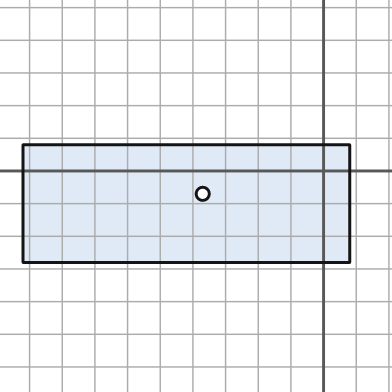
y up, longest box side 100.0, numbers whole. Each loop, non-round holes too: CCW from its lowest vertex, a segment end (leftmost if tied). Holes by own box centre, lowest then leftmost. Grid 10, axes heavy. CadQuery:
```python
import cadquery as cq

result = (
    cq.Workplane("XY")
    .moveTo(-92.0, -28.0)
    .lineTo(8.0, -28.0)
    .lineTo(8.0, 8.0)
    .lineTo(-92.0, 8.0)
    .close()
    .moveTo(-37.0, -7.0)
    .circle(2.0)
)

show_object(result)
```